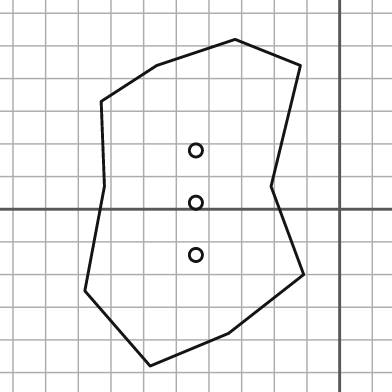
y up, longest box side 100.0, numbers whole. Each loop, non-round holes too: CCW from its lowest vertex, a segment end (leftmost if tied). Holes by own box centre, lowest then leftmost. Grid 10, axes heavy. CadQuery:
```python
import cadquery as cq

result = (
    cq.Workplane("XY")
    .moveTo(-58.0, -48.0)
    .lineTo(-34.0, -38.0)
    .lineTo(-11.0, -20.0)
    .lineTo(-21.0, 7.0)
    .lineTo(-12.0, 44.0)
    .lineTo(-32.0, 52.0)
    .lineTo(-56.0, 44.0)
    .lineTo(-73.0, 33.0)
    .lineTo(-72.0, 7.0)
    .lineTo(-78.0, -25.0)
    .close()
    .moveTo(-44.0, -14.0)
    .circle(2.0)
    .moveTo(-44.0, 2.0)
    .circle(2.0)
    .moveTo(-44.0, 18.0)
    .circle(2.0)
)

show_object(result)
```